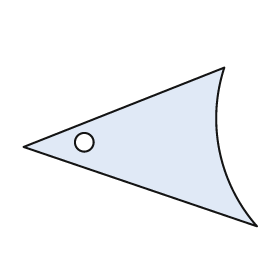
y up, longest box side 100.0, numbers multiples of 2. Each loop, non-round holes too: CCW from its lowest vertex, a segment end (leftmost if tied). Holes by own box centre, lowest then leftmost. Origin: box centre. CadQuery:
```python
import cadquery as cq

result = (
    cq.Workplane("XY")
    .moveTo(50.0, -34.0)
    .threePointArc((34.0, -2.0), (36.0, 34.0))
    .lineTo(-50.0, 0.0)
    .close()
    .moveTo(-24.0, 2.0)
    .circle(4.0)
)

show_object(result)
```